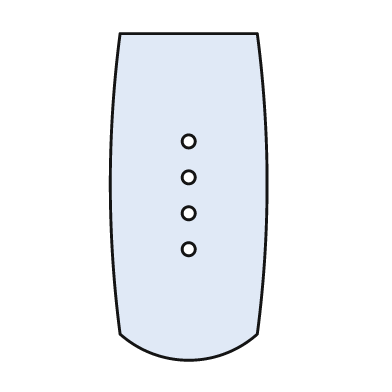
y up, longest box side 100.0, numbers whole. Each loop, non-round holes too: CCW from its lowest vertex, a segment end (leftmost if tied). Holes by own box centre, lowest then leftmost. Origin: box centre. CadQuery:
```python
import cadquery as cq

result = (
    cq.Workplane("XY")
    .moveTo(-21.0, -42.0)
    .threePointArc((0.0, -50.0), (21.0, -42.0))
    .threePointArc((24.0, 4.0), (21.0, 50.0))
    .lineTo(-21.0, 50.0)
    .threePointArc((-24.0, 4.0), (-21.0, -42.0))
    .close()
    .moveTo(0.0, -16.0)
    .circle(2.0)
    .moveTo(0.0, -5.0)
    .circle(2.0)
    .moveTo(0.0, 6.0)
    .circle(2.0)
    .moveTo(0.0, 17.0)
    .circle(2.0)
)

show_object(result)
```